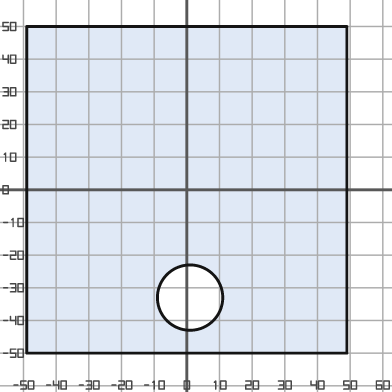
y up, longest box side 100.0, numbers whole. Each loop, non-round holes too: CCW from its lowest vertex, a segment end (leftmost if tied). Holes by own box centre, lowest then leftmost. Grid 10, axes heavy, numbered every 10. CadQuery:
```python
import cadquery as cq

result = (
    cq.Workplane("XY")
    .moveTo(-49.0, -50.0)
    .lineTo(49.0, -50.0)
    .lineTo(49.0, 50.0)
    .lineTo(-49.0, 50.0)
    .close()
    .moveTo(1.0, -33.0)
    .circle(10.0)
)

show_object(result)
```